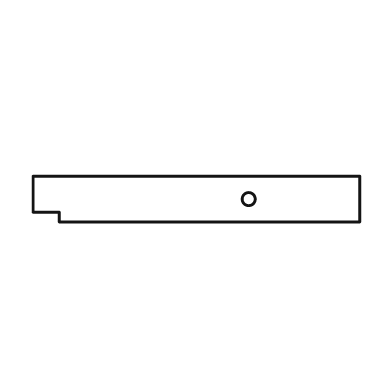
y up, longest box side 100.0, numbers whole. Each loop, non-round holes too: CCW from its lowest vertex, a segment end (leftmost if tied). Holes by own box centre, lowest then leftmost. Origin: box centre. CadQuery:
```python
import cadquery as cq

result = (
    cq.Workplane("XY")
    .moveTo(-42.0, -7.0)
    .lineTo(50.0, -7.0)
    .lineTo(50.0, 7.0)
    .lineTo(-50.0, 7.0)
    .lineTo(-50.0, -4.0)
    .lineTo(-42.0, -4.0)
    .close()
    .moveTo(16.0, 0.0)
    .circle(2.0)
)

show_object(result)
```